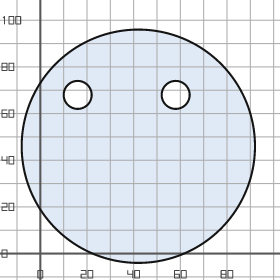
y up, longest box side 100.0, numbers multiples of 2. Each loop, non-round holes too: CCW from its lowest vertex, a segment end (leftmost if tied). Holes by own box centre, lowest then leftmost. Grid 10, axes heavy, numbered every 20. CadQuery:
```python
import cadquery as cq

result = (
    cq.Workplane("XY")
    .moveTo(42.0, 46.0)
    .circle(50.0)
    .moveTo(16.0, 68.0)
    .circle(6.0)
    .moveTo(58.0, 68.0)
    .circle(6.0)
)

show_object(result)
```